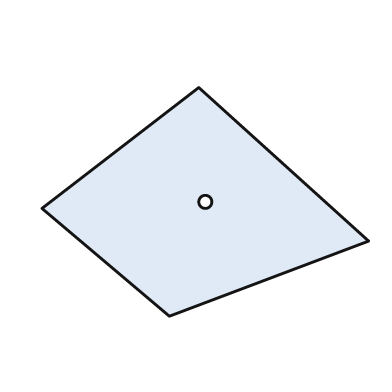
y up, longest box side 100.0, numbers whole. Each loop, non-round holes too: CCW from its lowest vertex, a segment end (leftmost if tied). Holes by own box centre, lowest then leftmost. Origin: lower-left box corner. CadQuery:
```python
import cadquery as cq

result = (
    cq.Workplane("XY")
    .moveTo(39.0, 0.0)
    .lineTo(100.0, 23.0)
    .lineTo(48.0, 70.0)
    .lineTo(0.0, 33.0)
    .close()
    .moveTo(50.0, 35.0)
    .circle(2.0)
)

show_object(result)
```